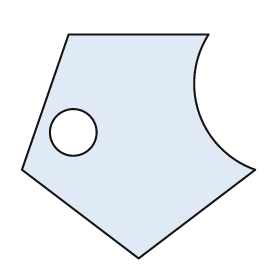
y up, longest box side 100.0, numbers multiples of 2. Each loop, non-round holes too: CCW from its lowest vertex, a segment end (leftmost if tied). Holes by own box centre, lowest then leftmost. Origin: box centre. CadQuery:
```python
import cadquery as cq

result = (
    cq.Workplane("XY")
    .moveTo(0.0, -48.0)
    .lineTo(50.0, -10.0)
    .threePointArc((26.0, 14.0), (30.0, 48.0))
    .lineTo(-30.0, 48.0)
    .lineTo(-50.0, -10.0)
    .close()
    .moveTo(-28.0, 6.0)
    .circle(10.0)
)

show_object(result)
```